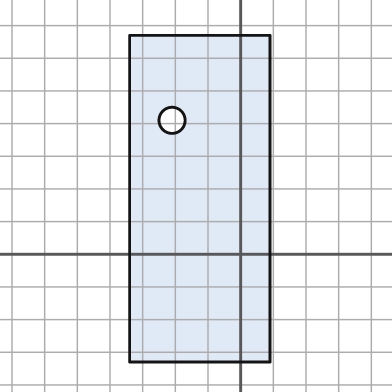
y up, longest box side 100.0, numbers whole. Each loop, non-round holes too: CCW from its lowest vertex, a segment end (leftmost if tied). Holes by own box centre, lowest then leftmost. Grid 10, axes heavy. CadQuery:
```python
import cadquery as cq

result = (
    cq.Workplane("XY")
    .moveTo(-34.0, -33.0)
    .lineTo(9.0, -33.0)
    .lineTo(9.0, 67.0)
    .lineTo(-34.0, 67.0)
    .close()
    .moveTo(-21.0, 41.0)
    .circle(4.0)
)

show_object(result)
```